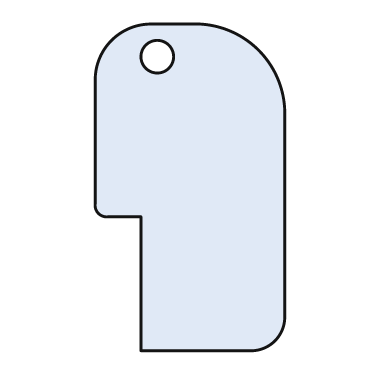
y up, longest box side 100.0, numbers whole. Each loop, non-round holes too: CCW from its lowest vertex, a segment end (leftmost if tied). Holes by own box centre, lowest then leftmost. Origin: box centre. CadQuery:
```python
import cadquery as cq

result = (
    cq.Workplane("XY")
    .moveTo(-15.0, -50.0)
    .lineTo(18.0, -50.0)
    .threePointArc((26.0, -47.0), (29.0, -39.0))
    .lineTo(29.0, 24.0)
    .threePointArc((21.0, 42.0), (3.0, 50.0))
    .lineTo(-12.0, 50.0)
    .threePointArc((-24.0, 45.0), (-29.0, 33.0))
    .lineTo(-29.0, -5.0)
    .threePointArc((-28.0, -8.0), (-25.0, -9.0))
    .lineTo(-15.0, -9.0)
    .close()
    .moveTo(-10.0, 40.0)
    .circle(5.0)
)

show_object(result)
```